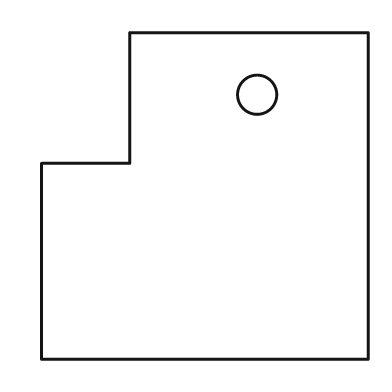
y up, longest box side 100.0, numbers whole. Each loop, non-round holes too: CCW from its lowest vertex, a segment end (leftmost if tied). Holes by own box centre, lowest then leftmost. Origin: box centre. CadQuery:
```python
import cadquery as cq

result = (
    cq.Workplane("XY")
    .moveTo(-50.0, -50.0)
    .lineTo(50.0, -50.0)
    .lineTo(50.0, 50.0)
    .lineTo(-23.0, 50.0)
    .lineTo(-23.0, 10.0)
    .lineTo(-50.0, 10.0)
    .close()
    .moveTo(16.0, 31.0)
    .circle(6.0)
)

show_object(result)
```